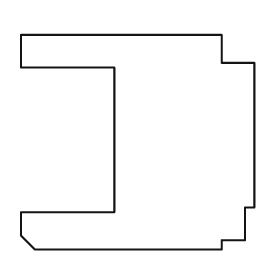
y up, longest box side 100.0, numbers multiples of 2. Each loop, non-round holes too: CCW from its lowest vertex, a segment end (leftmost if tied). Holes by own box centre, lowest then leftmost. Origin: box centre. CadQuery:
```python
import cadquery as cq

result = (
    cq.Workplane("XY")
    .moveTo(-44.0, -46.0)
    .lineTo(36.0, -46.0)
    .lineTo(36.0, -42.0)
    .lineTo(46.0, -42.0)
    .lineTo(46.0, -28.0)
    .lineTo(50.0, -28.0)
    .lineTo(50.0, 34.0)
    .lineTo(36.0, 34.0)
    .lineTo(36.0, 46.0)
    .lineTo(-50.0, 46.0)
    .lineTo(-50.0, 32.0)
    .lineTo(-10.0, 32.0)
    .lineTo(-10.0, -30.0)
    .lineTo(-50.0, -30.0)
    .lineTo(-50.0, -40.0)
    .close()
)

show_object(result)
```